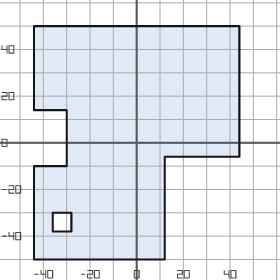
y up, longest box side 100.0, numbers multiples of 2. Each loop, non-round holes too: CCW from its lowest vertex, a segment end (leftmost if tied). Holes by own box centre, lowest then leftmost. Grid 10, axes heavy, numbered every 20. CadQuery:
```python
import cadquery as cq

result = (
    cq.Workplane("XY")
    .moveTo(-44.0, -50.0)
    .lineTo(12.0, -50.0)
    .lineTo(12.0, -6.0)
    .lineTo(44.0, -6.0)
    .lineTo(44.0, 50.0)
    .lineTo(-44.0, 50.0)
    .lineTo(-44.0, 14.0)
    .lineTo(-30.0, 14.0)
    .lineTo(-30.0, -10.0)
    .lineTo(-44.0, -10.0)
    .close()
    .moveTo(-36.0, -38.0)
    .lineTo(-28.0, -38.0)
    .lineTo(-28.0, -30.0)
    .lineTo(-36.0, -30.0)
    .close()
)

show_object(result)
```